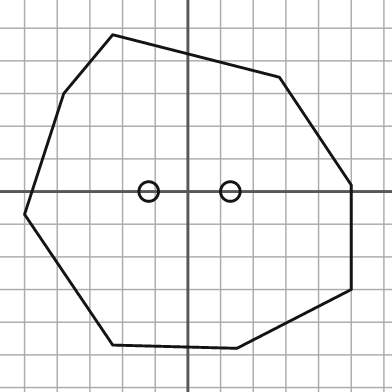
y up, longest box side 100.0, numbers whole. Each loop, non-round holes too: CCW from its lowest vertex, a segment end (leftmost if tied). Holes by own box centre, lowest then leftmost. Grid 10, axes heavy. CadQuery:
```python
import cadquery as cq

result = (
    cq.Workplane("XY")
    .moveTo(15.0, -48.0)
    .lineTo(50.0, -30.0)
    .lineTo(50.0, 2.0)
    .lineTo(28.0, 35.0)
    .lineTo(-23.0, 48.0)
    .lineTo(-38.0, 30.0)
    .lineTo(-50.0, -7.0)
    .lineTo(-23.0, -47.0)
    .close()
    .moveTo(-12.0, 0.0)
    .circle(3.0)
    .moveTo(13.0, 0.0)
    .circle(3.0)
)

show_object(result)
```